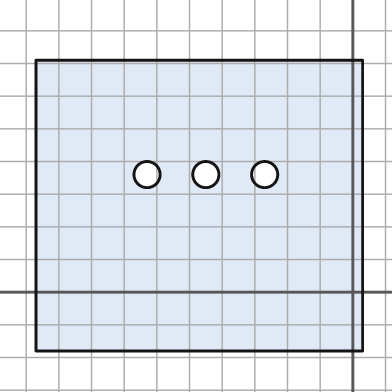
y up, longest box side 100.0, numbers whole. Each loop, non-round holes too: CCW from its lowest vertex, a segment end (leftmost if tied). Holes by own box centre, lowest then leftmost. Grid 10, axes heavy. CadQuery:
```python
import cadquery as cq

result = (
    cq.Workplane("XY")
    .moveTo(-97.0, -18.0)
    .lineTo(3.0, -18.0)
    .lineTo(3.0, 71.0)
    .lineTo(-97.0, 71.0)
    .close()
    .moveTo(-63.0, 36.0)
    .circle(4.0)
    .moveTo(-45.0, 36.0)
    .circle(4.0)
    .moveTo(-27.0, 36.0)
    .circle(4.0)
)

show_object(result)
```